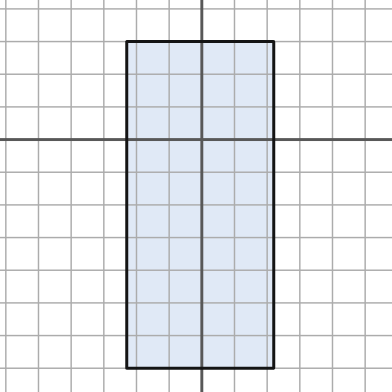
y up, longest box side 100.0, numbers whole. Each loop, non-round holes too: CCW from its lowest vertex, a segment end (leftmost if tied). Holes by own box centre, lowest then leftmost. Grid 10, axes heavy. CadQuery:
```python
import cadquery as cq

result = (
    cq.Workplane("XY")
    .moveTo(-23.0, -70.0)
    .lineTo(22.0, -70.0)
    .lineTo(22.0, 30.0)
    .lineTo(-23.0, 30.0)
    .close()
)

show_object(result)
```